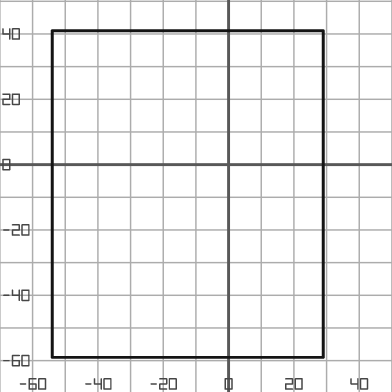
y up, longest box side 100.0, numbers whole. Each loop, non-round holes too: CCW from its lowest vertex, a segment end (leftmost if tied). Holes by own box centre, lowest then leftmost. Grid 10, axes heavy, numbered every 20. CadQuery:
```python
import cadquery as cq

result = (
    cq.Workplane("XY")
    .moveTo(-54.0, -59.0)
    .lineTo(29.0, -59.0)
    .lineTo(29.0, 41.0)
    .lineTo(-54.0, 41.0)
    .close()
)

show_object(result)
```